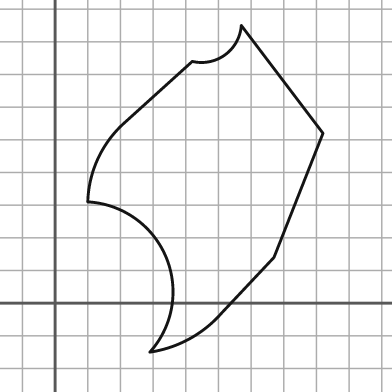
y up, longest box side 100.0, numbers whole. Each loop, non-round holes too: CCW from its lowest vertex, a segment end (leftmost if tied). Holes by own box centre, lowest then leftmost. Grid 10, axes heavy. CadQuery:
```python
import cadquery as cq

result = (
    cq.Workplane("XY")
    .moveTo(29.0, -15.0)
    .threePointArc((41.0, -11.0), (51.0, -3.0))
    .lineTo(67.0, 14.0)
    .lineTo(82.0, 52.0)
    .lineTo(57.0, 85.0)
    .threePointArc((52.0, 76.0), (42.0, 74.0))
    .lineTo(21.0, 55.0)
    .threePointArc((13.0, 44.0), (10.0, 31.0))
    .threePointArc((34.0, 14.0), (29.0, -15.0))
    .close()
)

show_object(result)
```